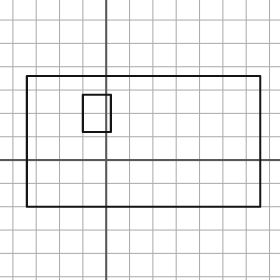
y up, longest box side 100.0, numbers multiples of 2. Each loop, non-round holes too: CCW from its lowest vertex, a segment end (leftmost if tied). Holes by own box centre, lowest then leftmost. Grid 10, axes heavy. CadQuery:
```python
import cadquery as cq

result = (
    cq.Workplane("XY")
    .moveTo(-34.0, -20.0)
    .lineTo(66.0, -20.0)
    .lineTo(66.0, 36.0)
    .lineTo(-34.0, 36.0)
    .close()
    .moveTo(-10.0, 12.0)
    .lineTo(2.0, 12.0)
    .lineTo(2.0, 28.0)
    .lineTo(-10.0, 28.0)
    .close()
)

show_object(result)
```